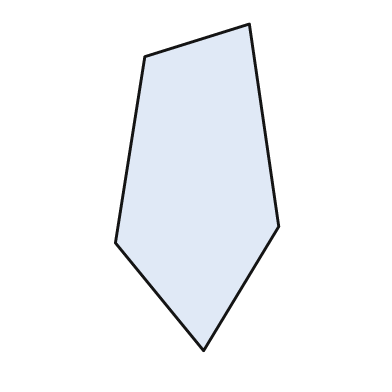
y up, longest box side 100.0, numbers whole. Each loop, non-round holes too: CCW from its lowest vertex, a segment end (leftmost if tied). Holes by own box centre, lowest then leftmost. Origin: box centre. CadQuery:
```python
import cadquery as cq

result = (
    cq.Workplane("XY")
    .moveTo(2.0, -50.0)
    .lineTo(25.0, -12.0)
    .lineTo(16.0, 50.0)
    .lineTo(-16.0, 40.0)
    .lineTo(-25.0, -17.0)
    .close()
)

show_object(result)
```